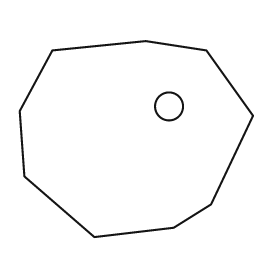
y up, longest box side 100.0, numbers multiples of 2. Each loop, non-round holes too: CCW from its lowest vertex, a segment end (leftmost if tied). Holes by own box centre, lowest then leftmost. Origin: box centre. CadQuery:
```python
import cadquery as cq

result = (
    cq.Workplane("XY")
    .moveTo(-18.0, -42.0)
    .lineTo(16.0, -38.0)
    .lineTo(32.0, -28.0)
    .lineTo(50.0, 10.0)
    .lineTo(30.0, 38.0)
    .lineTo(4.0, 42.0)
    .lineTo(-36.0, 38.0)
    .lineTo(-50.0, 12.0)
    .lineTo(-48.0, -16.0)
    .close()
    .moveTo(14.0, 14.0)
    .circle(6.0)
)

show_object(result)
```